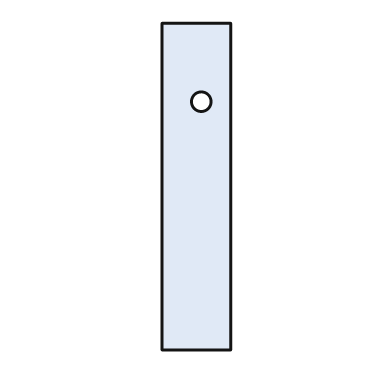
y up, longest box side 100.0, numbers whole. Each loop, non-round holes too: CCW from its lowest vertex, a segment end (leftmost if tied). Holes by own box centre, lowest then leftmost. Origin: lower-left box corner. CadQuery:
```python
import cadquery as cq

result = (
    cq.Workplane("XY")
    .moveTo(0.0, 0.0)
    .lineTo(21.0, 0.0)
    .lineTo(21.0, 100.0)
    .lineTo(0.0, 100.0)
    .close()
    .moveTo(12.0, 76.0)
    .circle(3.0)
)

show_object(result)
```